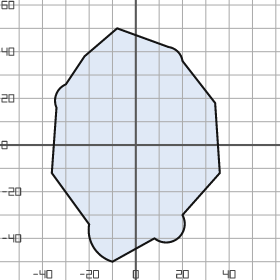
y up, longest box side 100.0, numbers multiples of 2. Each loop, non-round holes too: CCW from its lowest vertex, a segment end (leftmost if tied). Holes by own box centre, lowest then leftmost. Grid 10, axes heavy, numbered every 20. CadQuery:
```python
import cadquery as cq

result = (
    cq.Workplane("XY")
    .moveTo(-10.0, -50.0)
    .lineTo(8.0, -40.0)
    .threePointArc((18.0, -40.0), (20.0, -30.0))
    .lineTo(36.0, -12.0)
    .lineTo(34.0, 18.0)
    .lineTo(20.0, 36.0)
    .threePointArc((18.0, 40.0), (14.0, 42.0))
    .lineTo(-8.0, 50.0)
    .lineTo(-22.0, 38.0)
    .lineTo(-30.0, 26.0)
    .threePointArc((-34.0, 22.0), (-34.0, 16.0))
    .lineTo(-36.0, -12.0)
    .lineTo(-20.0, -34.0)
    .threePointArc((-18.0, -44.0), (-10.0, -50.0))
    .close()
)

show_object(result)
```